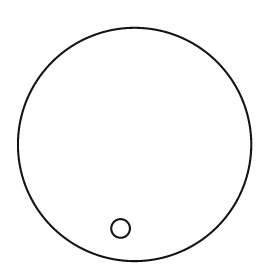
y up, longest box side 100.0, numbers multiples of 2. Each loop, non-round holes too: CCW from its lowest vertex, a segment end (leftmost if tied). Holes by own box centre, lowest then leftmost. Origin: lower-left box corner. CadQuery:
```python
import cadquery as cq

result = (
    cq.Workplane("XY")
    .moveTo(50.0, 50.0)
    .circle(50.0)
    .moveTo(44.0, 14.0)
    .circle(4.0)
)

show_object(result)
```